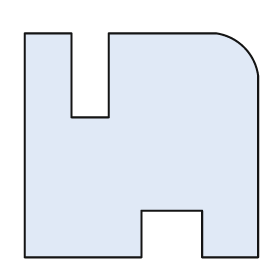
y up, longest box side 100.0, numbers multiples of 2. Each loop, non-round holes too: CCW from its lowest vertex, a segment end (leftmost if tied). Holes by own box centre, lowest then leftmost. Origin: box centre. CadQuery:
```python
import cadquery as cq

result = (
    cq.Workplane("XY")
    .moveTo(-50.0, -48.0)
    .lineTo(0.0, -48.0)
    .lineTo(0.0, -28.0)
    .lineTo(26.0, -28.0)
    .lineTo(26.0, -48.0)
    .lineTo(50.0, -48.0)
    .lineTo(50.0, 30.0)
    .threePointArc((44.0, 42.0), (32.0, 48.0))
    .lineTo(-14.0, 48.0)
    .lineTo(-14.0, 12.0)
    .lineTo(-30.0, 12.0)
    .lineTo(-30.0, 48.0)
    .lineTo(-50.0, 48.0)
    .close()
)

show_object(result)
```